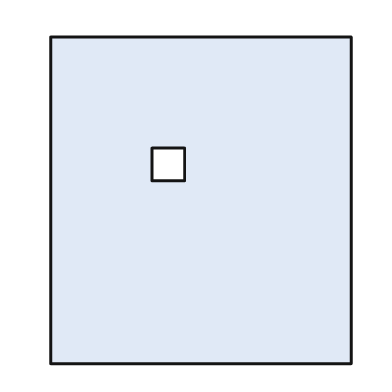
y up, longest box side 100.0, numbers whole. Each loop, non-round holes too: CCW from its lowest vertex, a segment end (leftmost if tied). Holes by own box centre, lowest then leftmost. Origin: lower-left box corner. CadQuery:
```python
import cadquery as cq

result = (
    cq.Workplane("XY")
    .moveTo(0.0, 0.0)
    .lineTo(92.0, 0.0)
    .lineTo(92.0, 100.0)
    .lineTo(0.0, 100.0)
    .close()
    .moveTo(31.0, 56.0)
    .lineTo(41.0, 56.0)
    .lineTo(41.0, 66.0)
    .lineTo(31.0, 66.0)
    .close()
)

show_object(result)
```